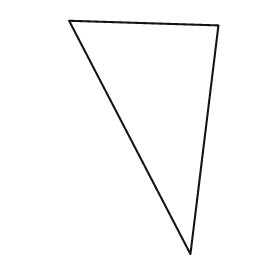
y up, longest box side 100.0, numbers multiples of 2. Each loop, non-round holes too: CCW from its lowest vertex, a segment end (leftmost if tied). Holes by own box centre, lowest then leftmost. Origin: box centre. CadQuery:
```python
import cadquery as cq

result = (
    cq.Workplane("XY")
    .moveTo(20.0, -50.0)
    .lineTo(32.0, 48.0)
    .lineTo(-32.0, 50.0)
    .close()
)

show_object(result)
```